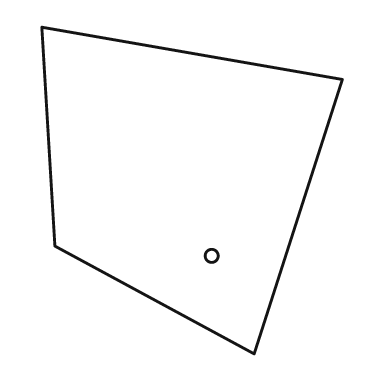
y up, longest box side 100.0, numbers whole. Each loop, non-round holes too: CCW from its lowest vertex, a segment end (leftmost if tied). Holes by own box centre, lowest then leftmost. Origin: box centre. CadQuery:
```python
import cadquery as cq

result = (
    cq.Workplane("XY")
    .moveTo(19.0, -50.0)
    .lineTo(46.0, 34.0)
    .lineTo(-46.0, 50.0)
    .lineTo(-42.0, -17.0)
    .close()
    .moveTo(6.0, -20.0)
    .circle(2.0)
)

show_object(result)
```